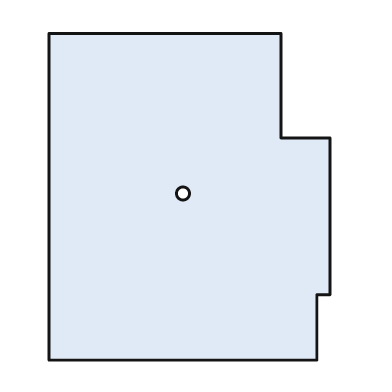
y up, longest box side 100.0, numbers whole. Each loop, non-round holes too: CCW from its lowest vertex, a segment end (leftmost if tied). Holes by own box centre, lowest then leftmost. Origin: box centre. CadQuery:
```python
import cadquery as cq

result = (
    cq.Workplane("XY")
    .moveTo(-43.0, -50.0)
    .lineTo(39.0, -50.0)
    .lineTo(39.0, -30.0)
    .lineTo(43.0, -30.0)
    .lineTo(43.0, 18.0)
    .lineTo(28.0, 18.0)
    .lineTo(28.0, 50.0)
    .lineTo(-43.0, 50.0)
    .close()
    .moveTo(-2.0, 1.0)
    .circle(2.0)
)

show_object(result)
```